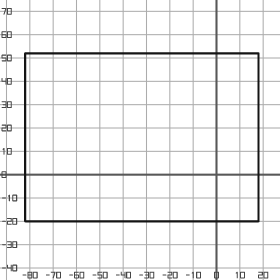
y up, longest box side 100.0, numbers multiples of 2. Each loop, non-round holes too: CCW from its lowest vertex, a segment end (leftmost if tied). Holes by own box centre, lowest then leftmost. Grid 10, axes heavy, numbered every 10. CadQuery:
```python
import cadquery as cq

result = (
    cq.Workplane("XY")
    .moveTo(-82.0, -20.0)
    .lineTo(18.0, -20.0)
    .lineTo(18.0, 52.0)
    .lineTo(-82.0, 52.0)
    .close()
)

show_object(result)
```